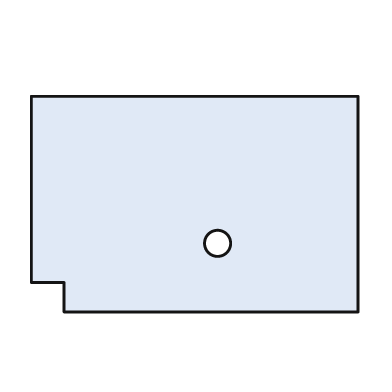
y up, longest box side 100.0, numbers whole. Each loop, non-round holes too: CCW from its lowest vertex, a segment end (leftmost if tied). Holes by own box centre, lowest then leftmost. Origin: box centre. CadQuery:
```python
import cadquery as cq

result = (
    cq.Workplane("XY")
    .moveTo(-40.0, -33.0)
    .lineTo(50.0, -33.0)
    .lineTo(50.0, 33.0)
    .lineTo(-50.0, 33.0)
    .lineTo(-50.0, -24.0)
    .lineTo(-40.0, -24.0)
    .close()
    .moveTo(7.0, -12.0)
    .circle(4.0)
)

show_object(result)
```